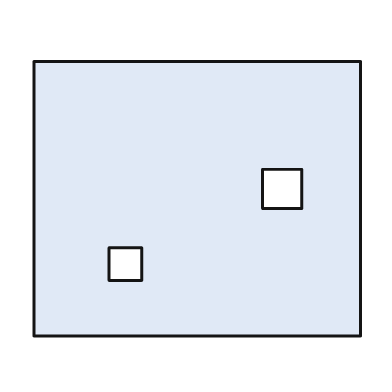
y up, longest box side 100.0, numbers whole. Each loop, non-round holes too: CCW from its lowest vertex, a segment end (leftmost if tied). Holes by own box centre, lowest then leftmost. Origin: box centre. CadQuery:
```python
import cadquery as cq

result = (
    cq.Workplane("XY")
    .moveTo(-50.0, -42.0)
    .lineTo(50.0, -42.0)
    .lineTo(50.0, 42.0)
    .lineTo(-50.0, 42.0)
    .close()
    .moveTo(-27.0, -25.0)
    .lineTo(-17.0, -25.0)
    .lineTo(-17.0, -15.0)
    .lineTo(-27.0, -15.0)
    .close()
    .moveTo(20.0, -3.0)
    .lineTo(32.0, -3.0)
    .lineTo(32.0, 9.0)
    .lineTo(20.0, 9.0)
    .close()
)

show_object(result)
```